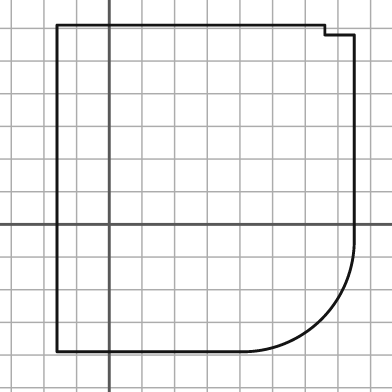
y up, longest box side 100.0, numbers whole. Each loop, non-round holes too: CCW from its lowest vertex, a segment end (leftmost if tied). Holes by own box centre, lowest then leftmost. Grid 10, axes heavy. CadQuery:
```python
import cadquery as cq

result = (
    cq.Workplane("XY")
    .moveTo(-16.0, -39.0)
    .lineTo(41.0, -39.0)
    .threePointArc((65.0, -29.0), (75.0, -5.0))
    .lineTo(75.0, 58.0)
    .lineTo(66.0, 58.0)
    .lineTo(66.0, 61.0)
    .lineTo(-16.0, 61.0)
    .close()
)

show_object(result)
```